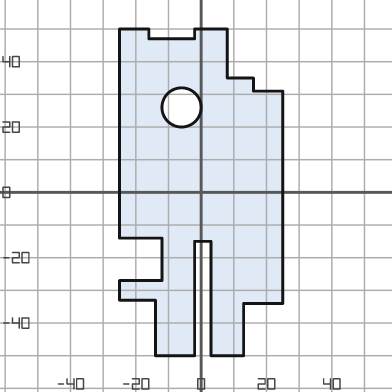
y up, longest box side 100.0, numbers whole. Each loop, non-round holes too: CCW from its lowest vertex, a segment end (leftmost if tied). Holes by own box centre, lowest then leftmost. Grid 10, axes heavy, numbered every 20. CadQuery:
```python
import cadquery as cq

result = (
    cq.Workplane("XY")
    .moveTo(-14.0, -50.0)
    .lineTo(-2.0, -50.0)
    .lineTo(-2.0, -15.0)
    .lineTo(3.0, -15.0)
    .lineTo(3.0, -50.0)
    .lineTo(13.0, -50.0)
    .lineTo(13.0, -34.0)
    .lineTo(25.0, -34.0)
    .lineTo(25.0, 31.0)
    .lineTo(16.0, 31.0)
    .lineTo(16.0, 35.0)
    .lineTo(8.0, 35.0)
    .lineTo(8.0, 50.0)
    .lineTo(-2.0, 50.0)
    .lineTo(-2.0, 47.0)
    .lineTo(-16.0, 47.0)
    .lineTo(-16.0, 50.0)
    .lineTo(-25.0, 50.0)
    .lineTo(-25.0, -14.0)
    .lineTo(-12.0, -14.0)
    .lineTo(-12.0, -27.0)
    .lineTo(-25.0, -27.0)
    .lineTo(-25.0, -33.0)
    .lineTo(-14.0, -33.0)
    .close()
    .moveTo(-6.0, 26.0)
    .circle(6.0)
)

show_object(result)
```